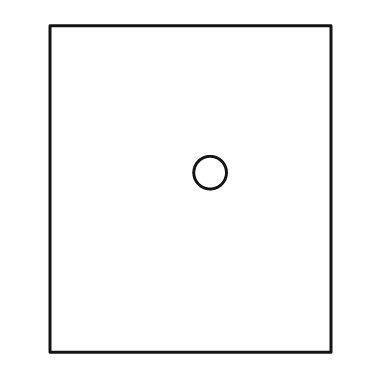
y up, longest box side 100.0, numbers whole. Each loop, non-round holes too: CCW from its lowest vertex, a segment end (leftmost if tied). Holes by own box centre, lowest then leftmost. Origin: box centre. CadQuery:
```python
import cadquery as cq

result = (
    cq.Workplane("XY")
    .moveTo(-43.0, -50.0)
    .lineTo(43.0, -50.0)
    .lineTo(43.0, 50.0)
    .lineTo(-43.0, 50.0)
    .close()
    .moveTo(6.0, 5.0)
    .circle(5.0)
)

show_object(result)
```